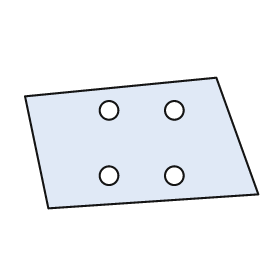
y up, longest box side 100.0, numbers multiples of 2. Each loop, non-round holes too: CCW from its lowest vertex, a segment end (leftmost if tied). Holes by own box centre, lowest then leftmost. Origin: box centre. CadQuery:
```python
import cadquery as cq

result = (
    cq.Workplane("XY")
    .moveTo(-40.0, -28.0)
    .lineTo(50.0, -22.0)
    .lineTo(32.0, 28.0)
    .lineTo(-50.0, 20.0)
    .close()
    .moveTo(-14.0, -14.0)
    .circle(4.0)
    .moveTo(14.0, -14.0)
    .circle(4.0)
    .moveTo(-14.0, 14.0)
    .circle(4.0)
    .moveTo(14.0, 14.0)
    .circle(4.0)
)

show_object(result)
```